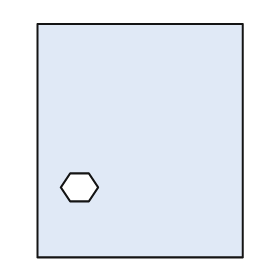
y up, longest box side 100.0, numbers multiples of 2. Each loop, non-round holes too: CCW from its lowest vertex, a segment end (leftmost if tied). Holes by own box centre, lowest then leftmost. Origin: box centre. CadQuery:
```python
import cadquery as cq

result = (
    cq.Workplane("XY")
    .moveTo(-44.0, -50.0)
    .lineTo(44.0, -50.0)
    .lineTo(44.0, 50.0)
    .lineTo(-44.0, 50.0)
    .close()
    .moveTo(-30.0, -26.0)
    .lineTo(-22.0, -26.0)
    .lineTo(-18.0, -20.0)
    .lineTo(-22.0, -14.0)
    .lineTo(-30.0, -14.0)
    .lineTo(-34.0, -20.0)
    .close()
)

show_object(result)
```